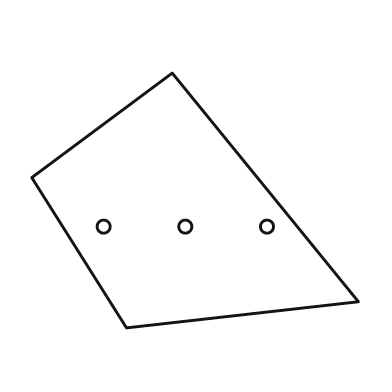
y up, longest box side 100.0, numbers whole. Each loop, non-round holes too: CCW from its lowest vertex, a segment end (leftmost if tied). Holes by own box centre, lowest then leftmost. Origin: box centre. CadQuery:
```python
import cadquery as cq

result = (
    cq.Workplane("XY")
    .moveTo(-21.0, -39.0)
    .lineTo(50.0, -31.0)
    .lineTo(-7.0, 39.0)
    .lineTo(-50.0, 7.0)
    .close()
    .moveTo(-28.0, -8.0)
    .circle(2.0)
    .moveTo(-3.0, -8.0)
    .circle(2.0)
    .moveTo(22.0, -8.0)
    .circle(2.0)
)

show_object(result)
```